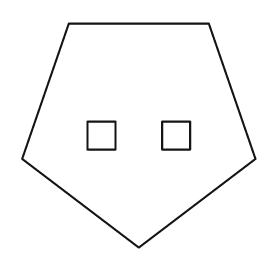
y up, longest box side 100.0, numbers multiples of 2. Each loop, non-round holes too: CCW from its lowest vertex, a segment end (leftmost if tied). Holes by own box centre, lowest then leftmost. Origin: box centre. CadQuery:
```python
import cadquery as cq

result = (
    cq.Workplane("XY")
    .moveTo(0.0, -48.0)
    .lineTo(50.0, -10.0)
    .lineTo(30.0, 48.0)
    .lineTo(-30.0, 48.0)
    .lineTo(-50.0, -10.0)
    .close()
    .moveTo(-22.0, -6.0)
    .lineTo(-10.0, -6.0)
    .lineTo(-10.0, 6.0)
    .lineTo(-22.0, 6.0)
    .close()
    .moveTo(10.0, -6.0)
    .lineTo(22.0, -6.0)
    .lineTo(22.0, 6.0)
    .lineTo(10.0, 6.0)
    .close()
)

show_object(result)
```